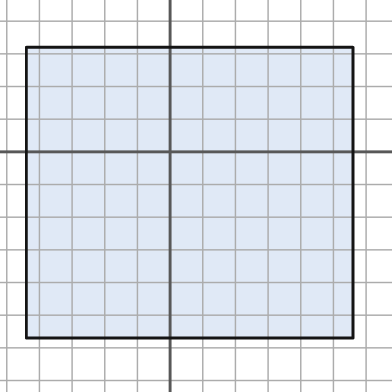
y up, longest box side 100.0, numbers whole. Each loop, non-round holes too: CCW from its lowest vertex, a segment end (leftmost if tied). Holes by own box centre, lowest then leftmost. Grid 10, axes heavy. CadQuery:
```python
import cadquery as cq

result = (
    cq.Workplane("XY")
    .moveTo(-44.0, -57.0)
    .lineTo(56.0, -57.0)
    .lineTo(56.0, 32.0)
    .lineTo(-44.0, 32.0)
    .close()
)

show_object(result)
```